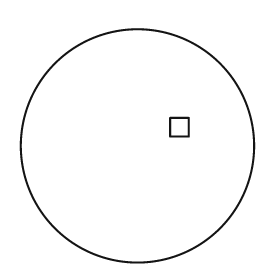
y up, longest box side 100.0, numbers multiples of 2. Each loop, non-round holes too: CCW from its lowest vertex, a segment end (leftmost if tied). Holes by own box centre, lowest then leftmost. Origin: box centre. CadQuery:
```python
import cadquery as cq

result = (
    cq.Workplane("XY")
    .moveTo(0.0, 0.0)
    .circle(50.0)
    .moveTo(14.0, 4.0)
    .lineTo(22.0, 4.0)
    .lineTo(22.0, 12.0)
    .lineTo(14.0, 12.0)
    .close()
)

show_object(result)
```